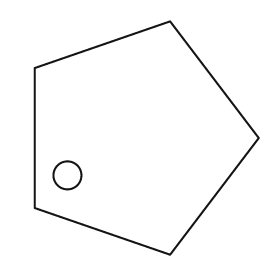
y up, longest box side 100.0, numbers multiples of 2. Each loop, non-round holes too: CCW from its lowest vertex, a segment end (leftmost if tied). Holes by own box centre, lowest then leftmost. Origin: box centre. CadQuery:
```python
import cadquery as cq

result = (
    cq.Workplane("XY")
    .moveTo(10.0, -50.0)
    .lineTo(48.0, 0.0)
    .lineTo(10.0, 50.0)
    .lineTo(-48.0, 30.0)
    .lineTo(-48.0, -30.0)
    .close()
    .moveTo(-34.0, -16.0)
    .circle(6.0)
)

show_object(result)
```